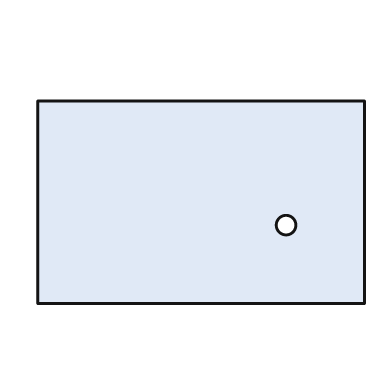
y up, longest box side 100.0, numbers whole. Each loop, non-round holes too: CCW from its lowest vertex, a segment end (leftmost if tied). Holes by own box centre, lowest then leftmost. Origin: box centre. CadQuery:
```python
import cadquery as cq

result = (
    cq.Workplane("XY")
    .moveTo(-50.0, -31.0)
    .lineTo(50.0, -31.0)
    .lineTo(50.0, 31.0)
    .lineTo(-50.0, 31.0)
    .close()
    .moveTo(26.0, -7.0)
    .circle(3.0)
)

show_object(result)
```